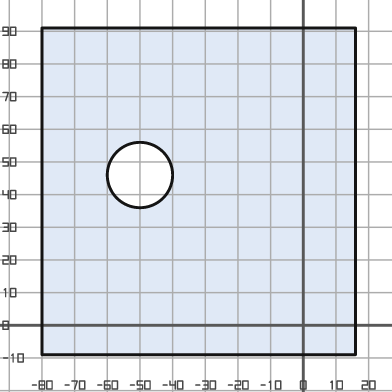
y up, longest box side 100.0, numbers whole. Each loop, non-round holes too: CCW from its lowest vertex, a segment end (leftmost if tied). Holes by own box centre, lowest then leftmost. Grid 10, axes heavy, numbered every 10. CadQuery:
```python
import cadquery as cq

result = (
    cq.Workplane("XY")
    .moveTo(-80.0, -9.0)
    .lineTo(16.0, -9.0)
    .lineTo(16.0, 91.0)
    .lineTo(-80.0, 91.0)
    .close()
    .moveTo(-50.0, 46.0)
    .circle(10.0)
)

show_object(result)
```